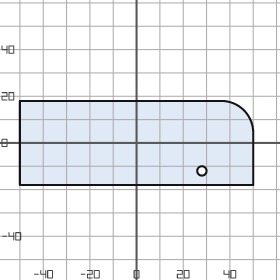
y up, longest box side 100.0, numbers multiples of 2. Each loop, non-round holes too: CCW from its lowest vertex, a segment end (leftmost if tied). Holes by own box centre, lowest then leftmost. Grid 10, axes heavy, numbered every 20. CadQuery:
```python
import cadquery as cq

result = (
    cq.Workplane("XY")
    .moveTo(-50.0, -18.0)
    .lineTo(50.0, -18.0)
    .lineTo(50.0, 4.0)
    .threePointArc((46.0, 14.0), (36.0, 18.0))
    .lineTo(-50.0, 18.0)
    .close()
    .moveTo(28.0, -12.0)
    .circle(2.0)
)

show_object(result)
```